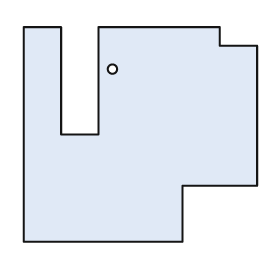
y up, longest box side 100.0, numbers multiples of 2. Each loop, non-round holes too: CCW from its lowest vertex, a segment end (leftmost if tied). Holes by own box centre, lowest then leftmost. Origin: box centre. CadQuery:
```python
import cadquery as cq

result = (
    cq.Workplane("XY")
    .moveTo(-50.0, -46.0)
    .lineTo(18.0, -46.0)
    .lineTo(18.0, -22.0)
    .lineTo(50.0, -22.0)
    .lineTo(50.0, 38.0)
    .lineTo(34.0, 38.0)
    .lineTo(34.0, 46.0)
    .lineTo(-18.0, 46.0)
    .lineTo(-18.0, 0.0)
    .lineTo(-34.0, 0.0)
    .lineTo(-34.0, 46.0)
    .lineTo(-50.0, 46.0)
    .close()
    .moveTo(-12.0, 28.0)
    .circle(2.0)
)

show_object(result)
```